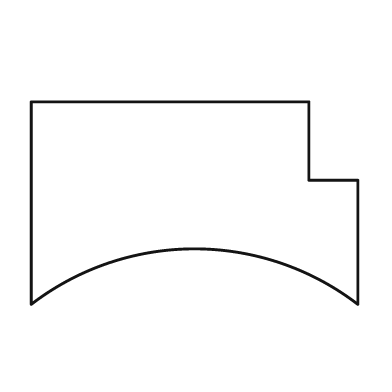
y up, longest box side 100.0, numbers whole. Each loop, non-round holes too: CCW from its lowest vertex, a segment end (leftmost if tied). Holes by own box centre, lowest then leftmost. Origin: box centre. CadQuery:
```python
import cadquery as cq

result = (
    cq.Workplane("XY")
    .moveTo(-50.0, -31.0)
    .threePointArc((0.0, -14.0), (50.0, -31.0))
    .lineTo(50.0, 7.0)
    .lineTo(35.0, 7.0)
    .lineTo(35.0, 31.0)
    .lineTo(-50.0, 31.0)
    .close()
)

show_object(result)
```